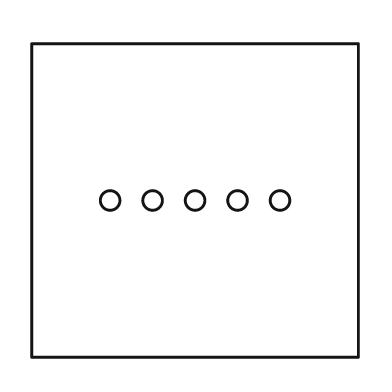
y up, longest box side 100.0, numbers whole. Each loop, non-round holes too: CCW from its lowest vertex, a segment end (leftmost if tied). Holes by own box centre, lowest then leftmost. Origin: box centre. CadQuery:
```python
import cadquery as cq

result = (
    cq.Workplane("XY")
    .moveTo(-50.0, -48.0)
    .lineTo(50.0, -48.0)
    .lineTo(50.0, 48.0)
    .lineTo(-50.0, 48.0)
    .close()
    .moveTo(-26.0, 0.0)
    .circle(3.0)
    .moveTo(-13.0, 0.0)
    .circle(3.0)
    .moveTo(0.0, 0.0)
    .circle(3.0)
    .moveTo(13.0, 0.0)
    .circle(3.0)
    .moveTo(26.0, 0.0)
    .circle(3.0)
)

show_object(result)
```